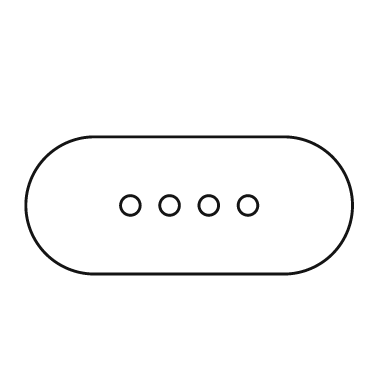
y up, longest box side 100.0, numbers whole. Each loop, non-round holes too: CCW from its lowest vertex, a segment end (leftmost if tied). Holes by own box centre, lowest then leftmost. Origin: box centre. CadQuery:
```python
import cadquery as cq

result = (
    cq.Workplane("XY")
    .moveTo(-29.0, -21.0)
    .lineTo(29.0, -21.0)
    .threePointArc((50.0, 0.0), (29.0, 21.0))
    .lineTo(-29.0, 21.0)
    .threePointArc((-50.0, 0.0), (-29.0, -21.0))
    .close()
    .moveTo(-18.0, 0.0)
    .circle(3.0)
    .moveTo(-6.0, 0.0)
    .circle(3.0)
    .moveTo(6.0, 0.0)
    .circle(3.0)
    .moveTo(18.0, 0.0)
    .circle(3.0)
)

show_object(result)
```